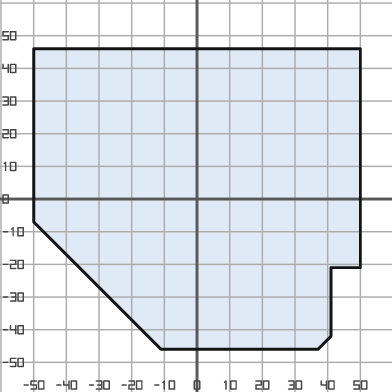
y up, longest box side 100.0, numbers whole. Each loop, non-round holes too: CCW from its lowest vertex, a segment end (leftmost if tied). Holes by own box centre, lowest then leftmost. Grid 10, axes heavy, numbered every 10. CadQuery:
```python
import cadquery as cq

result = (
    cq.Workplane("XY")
    .moveTo(-11.0, -46.0)
    .lineTo(37.0, -46.0)
    .lineTo(41.0, -42.0)
    .lineTo(41.0, -21.0)
    .lineTo(50.0, -21.0)
    .lineTo(50.0, 46.0)
    .lineTo(-50.0, 46.0)
    .lineTo(-50.0, -7.0)
    .close()
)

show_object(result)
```